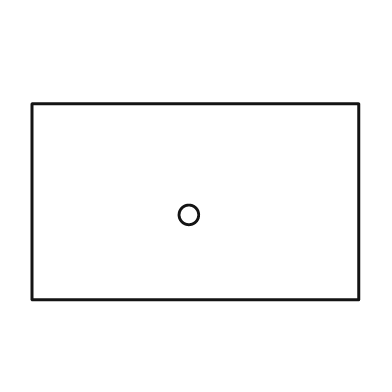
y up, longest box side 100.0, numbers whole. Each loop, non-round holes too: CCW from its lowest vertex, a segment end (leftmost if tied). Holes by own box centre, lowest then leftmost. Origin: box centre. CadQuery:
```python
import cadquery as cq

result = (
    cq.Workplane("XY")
    .moveTo(-50.0, -30.0)
    .lineTo(50.0, -30.0)
    .lineTo(50.0, 30.0)
    .lineTo(-50.0, 30.0)
    .close()
    .moveTo(-2.0, -4.0)
    .circle(3.0)
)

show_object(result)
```